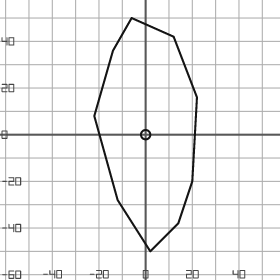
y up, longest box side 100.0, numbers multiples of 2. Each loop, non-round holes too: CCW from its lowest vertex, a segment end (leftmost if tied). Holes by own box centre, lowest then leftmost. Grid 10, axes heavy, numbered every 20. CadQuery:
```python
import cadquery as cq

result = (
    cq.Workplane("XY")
    .moveTo(2.0, -50.0)
    .lineTo(14.0, -38.0)
    .lineTo(20.0, -20.0)
    .lineTo(22.0, 16.0)
    .lineTo(12.0, 42.0)
    .lineTo(-6.0, 50.0)
    .lineTo(-14.0, 36.0)
    .lineTo(-22.0, 8.0)
    .lineTo(-12.0, -28.0)
    .close()
    .moveTo(0.0, 0.0)
    .circle(2.0)
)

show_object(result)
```